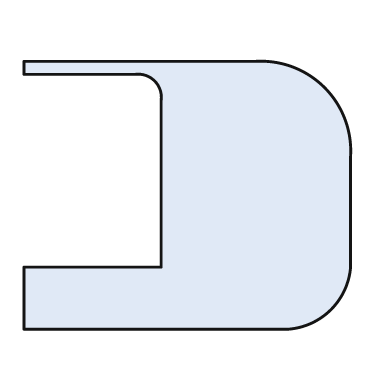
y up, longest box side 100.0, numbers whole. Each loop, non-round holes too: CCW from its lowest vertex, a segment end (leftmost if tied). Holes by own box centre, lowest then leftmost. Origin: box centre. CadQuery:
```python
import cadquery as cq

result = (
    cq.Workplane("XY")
    .moveTo(-50.0, -41.0)
    .lineTo(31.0, -41.0)
    .threePointArc((44.0, -35.0), (50.0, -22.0))
    .lineTo(50.0, 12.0)
    .threePointArc((42.0, 33.0), (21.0, 41.0))
    .lineTo(-50.0, 41.0)
    .lineTo(-50.0, 37.0)
    .lineTo(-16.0, 37.0)
    .threePointArc((-10.0, 35.0), (-8.0, 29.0))
    .lineTo(-8.0, -22.0)
    .lineTo(-50.0, -22.0)
    .close()
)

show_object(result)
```